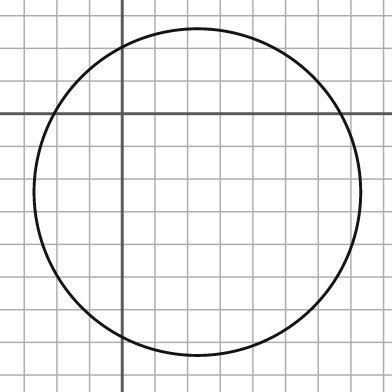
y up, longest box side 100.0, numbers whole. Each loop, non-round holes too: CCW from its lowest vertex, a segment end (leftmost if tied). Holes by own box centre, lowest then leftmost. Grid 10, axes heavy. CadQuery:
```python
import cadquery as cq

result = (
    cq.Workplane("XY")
    .moveTo(23.0, -24.0)
    .circle(50.0)
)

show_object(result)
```